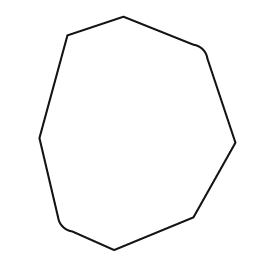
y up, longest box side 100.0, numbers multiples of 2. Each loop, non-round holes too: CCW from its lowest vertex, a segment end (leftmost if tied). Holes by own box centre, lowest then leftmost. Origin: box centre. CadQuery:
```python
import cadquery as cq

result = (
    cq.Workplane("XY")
    .moveTo(-10.0, -50.0)
    .lineTo(24.0, -36.0)
    .lineTo(42.0, -4.0)
    .lineTo(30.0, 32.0)
    .threePointArc((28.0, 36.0), (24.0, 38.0))
    .lineTo(-6.0, 50.0)
    .lineTo(-30.0, 42.0)
    .lineTo(-42.0, -2.0)
    .lineTo(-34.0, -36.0)
    .threePointArc((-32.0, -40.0), (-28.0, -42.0))
    .close()
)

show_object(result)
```